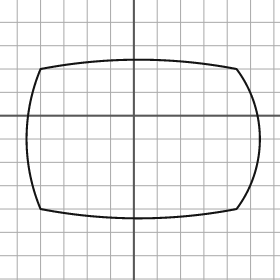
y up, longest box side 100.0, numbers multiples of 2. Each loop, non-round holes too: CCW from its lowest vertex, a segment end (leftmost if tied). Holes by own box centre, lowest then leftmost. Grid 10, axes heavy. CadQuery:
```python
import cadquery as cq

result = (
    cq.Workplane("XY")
    .moveTo(-40.0, -40.0)
    .threePointArc((2.0, -44.0), (44.0, -40.0))
    .threePointArc((54.0, -10.0), (44.0, 20.0))
    .threePointArc((2.0, 24.0), (-40.0, 20.0))
    .threePointArc((-46.0, -10.0), (-40.0, -40.0))
    .close()
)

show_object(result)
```